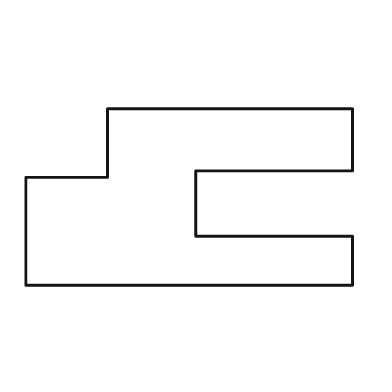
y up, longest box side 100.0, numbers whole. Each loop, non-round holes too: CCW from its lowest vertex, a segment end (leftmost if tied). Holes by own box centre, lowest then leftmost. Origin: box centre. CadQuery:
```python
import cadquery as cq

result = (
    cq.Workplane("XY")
    .moveTo(-50.0, -27.0)
    .lineTo(50.0, -27.0)
    .lineTo(50.0, -12.0)
    .lineTo(2.0, -12.0)
    .lineTo(2.0, 8.0)
    .lineTo(50.0, 8.0)
    .lineTo(50.0, 27.0)
    .lineTo(-25.0, 27.0)
    .lineTo(-25.0, 6.0)
    .lineTo(-50.0, 6.0)
    .close()
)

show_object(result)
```